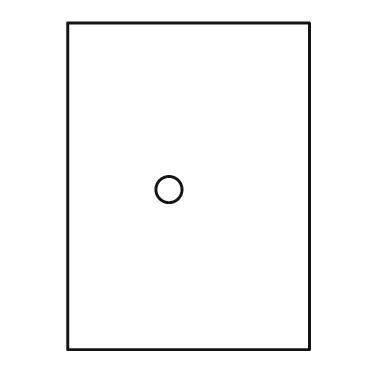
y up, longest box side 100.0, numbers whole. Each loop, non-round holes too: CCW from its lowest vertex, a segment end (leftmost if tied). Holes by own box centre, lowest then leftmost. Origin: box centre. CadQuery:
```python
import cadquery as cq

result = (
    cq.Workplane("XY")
    .moveTo(-37.0, -50.0)
    .lineTo(37.0, -50.0)
    .lineTo(37.0, 50.0)
    .lineTo(-37.0, 50.0)
    .close()
    .moveTo(-6.0, -1.0)
    .circle(4.0)
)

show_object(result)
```